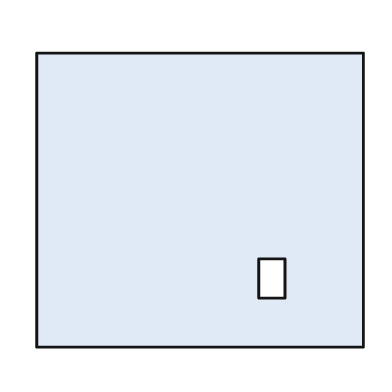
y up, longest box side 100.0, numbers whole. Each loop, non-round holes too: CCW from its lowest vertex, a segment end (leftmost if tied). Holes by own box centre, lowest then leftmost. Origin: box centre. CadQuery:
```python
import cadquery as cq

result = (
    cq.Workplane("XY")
    .moveTo(-50.0, -45.0)
    .lineTo(50.0, -45.0)
    .lineTo(50.0, 45.0)
    .lineTo(-50.0, 45.0)
    .close()
    .moveTo(18.0, -30.0)
    .lineTo(26.0, -30.0)
    .lineTo(26.0, -18.0)
    .lineTo(18.0, -18.0)
    .close()
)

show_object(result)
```